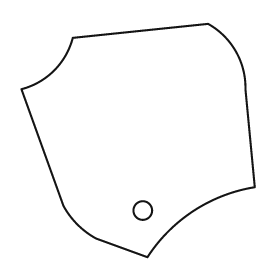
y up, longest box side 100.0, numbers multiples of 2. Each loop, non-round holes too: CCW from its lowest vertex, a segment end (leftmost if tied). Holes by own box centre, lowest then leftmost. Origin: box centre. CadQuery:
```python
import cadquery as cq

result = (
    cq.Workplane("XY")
    .moveTo(4.0, -50.0)
    .threePointArc((24.0, -30.0), (50.0, -20.0))
    .lineTo(46.0, 22.0)
    .threePointArc((42.0, 38.0), (30.0, 50.0))
    .lineTo(-28.0, 44.0)
    .threePointArc((-36.0, 30.0), (-50.0, 22.0))
    .lineTo(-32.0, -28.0)
    .threePointArc((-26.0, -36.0), (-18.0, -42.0))
    .close()
    .moveTo(2.0, -30.0)
    .circle(4.0)
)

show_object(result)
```